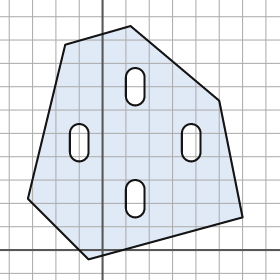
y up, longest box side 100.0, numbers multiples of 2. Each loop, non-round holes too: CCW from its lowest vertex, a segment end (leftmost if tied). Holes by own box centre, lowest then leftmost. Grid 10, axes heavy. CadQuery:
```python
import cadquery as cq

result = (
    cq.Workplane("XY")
    .moveTo(-6.0, -4.0)
    .lineTo(60.0, 14.0)
    .lineTo(50.0, 64.0)
    .lineTo(12.0, 96.0)
    .lineTo(-16.0, 88.0)
    .lineTo(-32.0, 22.0)
    .close()
    .moveTo(10.0, 18.0)
    .threePointArc((14.0, 14.0), (18.0, 18.0))
    .lineTo(18.0, 26.0)
    .threePointArc((14.0, 30.0), (10.0, 26.0))
    .close()
    .moveTo(-14.0, 42.0)
    .threePointArc((-10.0, 38.0), (-6.0, 42.0))
    .lineTo(-6.0, 50.0)
    .threePointArc((-10.0, 54.0), (-14.0, 50.0))
    .close()
    .moveTo(34.0, 42.0)
    .threePointArc((38.0, 38.0), (42.0, 42.0))
    .lineTo(42.0, 50.0)
    .threePointArc((38.0, 54.0), (34.0, 50.0))
    .close()
    .moveTo(10.0, 66.0)
    .threePointArc((14.0, 62.0), (18.0, 66.0))
    .lineTo(18.0, 74.0)
    .threePointArc((14.0, 78.0), (10.0, 74.0))
    .close()
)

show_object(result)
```